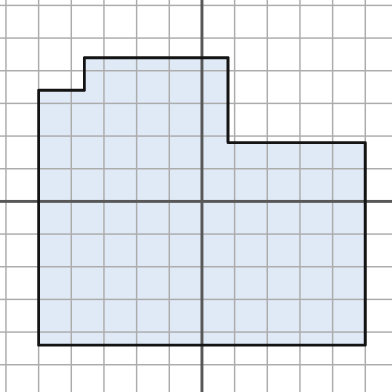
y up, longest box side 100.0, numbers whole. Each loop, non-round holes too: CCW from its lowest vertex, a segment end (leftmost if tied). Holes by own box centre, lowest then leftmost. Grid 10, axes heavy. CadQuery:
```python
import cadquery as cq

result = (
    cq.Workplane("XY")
    .moveTo(-50.0, -44.0)
    .lineTo(50.0, -44.0)
    .lineTo(50.0, 18.0)
    .lineTo(8.0, 18.0)
    .lineTo(8.0, 44.0)
    .lineTo(-36.0, 44.0)
    .lineTo(-36.0, 34.0)
    .lineTo(-50.0, 34.0)
    .close()
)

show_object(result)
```